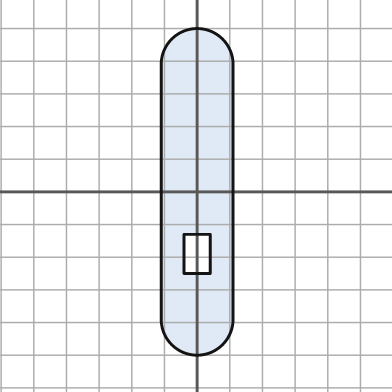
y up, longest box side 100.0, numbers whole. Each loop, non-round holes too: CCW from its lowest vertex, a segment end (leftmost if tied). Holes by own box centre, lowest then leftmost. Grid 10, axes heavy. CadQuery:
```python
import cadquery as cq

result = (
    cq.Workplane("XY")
    .moveTo(-11.0, -39.0)
    .threePointArc((0.0, -50.0), (11.0, -39.0))
    .lineTo(11.0, 39.0)
    .threePointArc((0.0, 50.0), (-11.0, 39.0))
    .close()
    .moveTo(-4.0, -25.0)
    .lineTo(4.0, -25.0)
    .lineTo(4.0, -13.0)
    .lineTo(-4.0, -13.0)
    .close()
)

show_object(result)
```